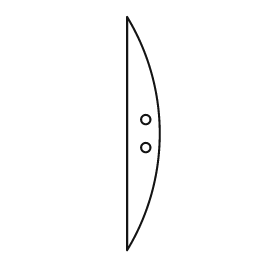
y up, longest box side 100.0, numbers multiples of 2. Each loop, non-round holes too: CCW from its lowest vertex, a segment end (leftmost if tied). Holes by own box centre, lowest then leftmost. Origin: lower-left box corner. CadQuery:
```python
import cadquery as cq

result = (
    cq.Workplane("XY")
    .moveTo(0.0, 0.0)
    .threePointArc((14.0, 50.0), (0.0, 100.0))
    .close()
    .moveTo(8.0, 44.0)
    .circle(2.0)
    .moveTo(8.0, 56.0)
    .circle(2.0)
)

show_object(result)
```